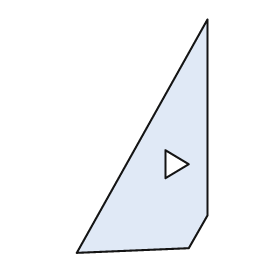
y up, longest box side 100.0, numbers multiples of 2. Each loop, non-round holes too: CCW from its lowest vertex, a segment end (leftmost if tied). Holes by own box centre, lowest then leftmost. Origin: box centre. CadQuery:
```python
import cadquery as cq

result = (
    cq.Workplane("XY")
    .moveTo(-28.0, -50.0)
    .lineTo(20.0, -48.0)
    .lineTo(28.0, -34.0)
    .lineTo(28.0, 50.0)
    .close()
    .moveTo(10.0, -18.0)
    .lineTo(20.0, -12.0)
    .lineTo(10.0, -6.0)
    .close()
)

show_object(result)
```